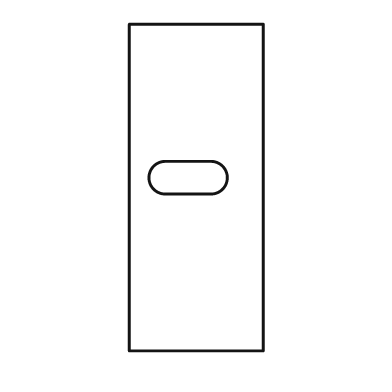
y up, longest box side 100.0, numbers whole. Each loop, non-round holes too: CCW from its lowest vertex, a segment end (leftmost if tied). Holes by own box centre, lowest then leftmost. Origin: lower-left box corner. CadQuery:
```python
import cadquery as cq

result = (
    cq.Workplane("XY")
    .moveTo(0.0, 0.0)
    .lineTo(41.0, 0.0)
    .lineTo(41.0, 100.0)
    .lineTo(0.0, 100.0)
    .close()
    .moveTo(11.0, 48.0)
    .lineTo(25.0, 48.0)
    .threePointArc((30.0, 53.0), (25.0, 58.0))
    .lineTo(11.0, 58.0)
    .threePointArc((6.0, 53.0), (11.0, 48.0))
    .close()
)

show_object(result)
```